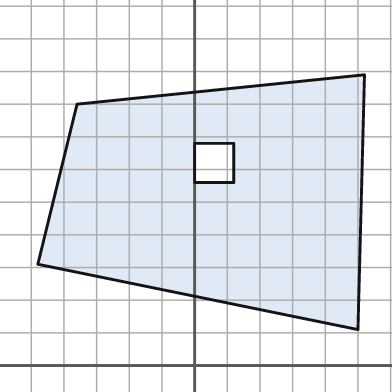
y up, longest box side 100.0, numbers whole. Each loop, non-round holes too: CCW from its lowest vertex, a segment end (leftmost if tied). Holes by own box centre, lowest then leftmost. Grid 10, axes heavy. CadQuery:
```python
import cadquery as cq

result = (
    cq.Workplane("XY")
    .moveTo(50.0, 11.0)
    .lineTo(52.0, 89.0)
    .lineTo(-36.0, 80.0)
    .lineTo(-48.0, 31.0)
    .close()
    .moveTo(0.0, 56.0)
    .lineTo(12.0, 56.0)
    .lineTo(12.0, 68.0)
    .lineTo(0.0, 68.0)
    .close()
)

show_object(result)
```